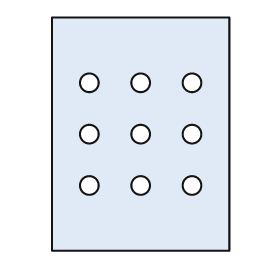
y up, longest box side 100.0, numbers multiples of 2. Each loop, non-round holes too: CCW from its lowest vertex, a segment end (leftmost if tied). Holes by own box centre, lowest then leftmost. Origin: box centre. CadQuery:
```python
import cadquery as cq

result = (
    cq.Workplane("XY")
    .moveTo(-38.0, -50.0)
    .lineTo(38.0, -50.0)
    .lineTo(38.0, 50.0)
    .lineTo(-38.0, 50.0)
    .close()
    .moveTo(-22.0, -22.0)
    .circle(4.0)
    .moveTo(0.0, -22.0)
    .circle(4.0)
    .moveTo(22.0, -22.0)
    .circle(4.0)
    .moveTo(-22.0, 0.0)
    .circle(4.0)
    .moveTo(0.0, 0.0)
    .circle(4.0)
    .moveTo(22.0, 0.0)
    .circle(4.0)
    .moveTo(-22.0, 22.0)
    .circle(4.0)
    .moveTo(0.0, 22.0)
    .circle(4.0)
    .moveTo(22.0, 22.0)
    .circle(4.0)
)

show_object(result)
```